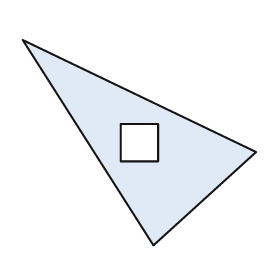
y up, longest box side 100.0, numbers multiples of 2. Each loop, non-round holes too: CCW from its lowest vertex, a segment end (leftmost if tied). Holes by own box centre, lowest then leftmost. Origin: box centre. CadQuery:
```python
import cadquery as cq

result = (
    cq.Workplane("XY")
    .moveTo(6.0, -44.0)
    .lineTo(50.0, -4.0)
    .lineTo(-50.0, 44.0)
    .close()
    .moveTo(-8.0, -8.0)
    .lineTo(8.0, -8.0)
    .lineTo(8.0, 8.0)
    .lineTo(-8.0, 8.0)
    .close()
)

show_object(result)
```